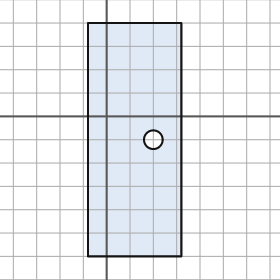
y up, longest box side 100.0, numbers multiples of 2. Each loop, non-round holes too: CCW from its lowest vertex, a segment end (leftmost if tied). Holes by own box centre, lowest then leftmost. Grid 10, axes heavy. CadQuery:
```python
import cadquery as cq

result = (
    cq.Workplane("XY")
    .moveTo(-8.0, -60.0)
    .lineTo(32.0, -60.0)
    .lineTo(32.0, 40.0)
    .lineTo(-8.0, 40.0)
    .close()
    .moveTo(20.0, -10.0)
    .circle(4.0)
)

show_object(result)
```